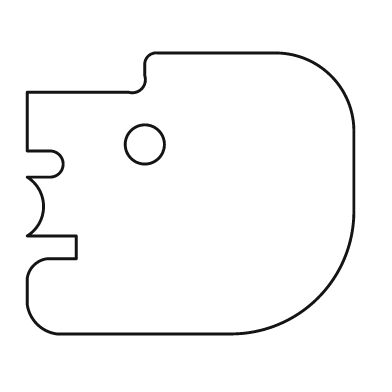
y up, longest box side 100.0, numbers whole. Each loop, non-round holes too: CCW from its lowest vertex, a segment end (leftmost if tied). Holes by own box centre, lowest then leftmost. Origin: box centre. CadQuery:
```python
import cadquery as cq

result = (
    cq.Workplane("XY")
    .moveTo(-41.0, -43.0)
    .lineTo(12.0, -43.0)
    .threePointArc((39.0, -32.0), (50.0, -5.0))
    .lineTo(50.0, 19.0)
    .threePointArc((43.0, 36.0), (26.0, 43.0))
    .lineTo(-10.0, 43.0)
    .threePointArc((-13.0, 42.0), (-14.0, 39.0))
    .lineTo(-14.0, 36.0)
    .threePointArc((-15.0, 32.0), (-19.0, 31.0))
    .lineTo(-50.0, 31.0)
    .lineTo(-50.0, 13.0)
    .lineTo(-43.0, 13.0)
    .threePointArc((-39.0, 9.0), (-43.0, 5.0))
    .lineTo(-50.0, 5.0)
    .threePointArc((-45.0, -4.0), (-50.0, -13.0))
    .lineTo(-35.0, -13.0)
    .lineTo(-35.0, -20.0)
    .lineTo(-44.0, -20.0)
    .threePointArc((-48.0, -22.0), (-50.0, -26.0))
    .lineTo(-50.0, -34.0)
    .threePointArc((-47.0, -40.0), (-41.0, -43.0))
    .close()
    .moveTo(-14.0, 15.0)
    .circle(6.0)
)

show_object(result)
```